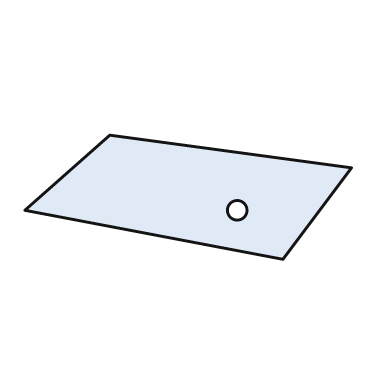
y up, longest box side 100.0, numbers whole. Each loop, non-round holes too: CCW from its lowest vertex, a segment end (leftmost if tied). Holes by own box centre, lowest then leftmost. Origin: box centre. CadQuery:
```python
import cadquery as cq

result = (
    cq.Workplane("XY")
    .moveTo(29.0, -19.0)
    .lineTo(50.0, 9.0)
    .lineTo(-24.0, 19.0)
    .lineTo(-50.0, -4.0)
    .close()
    .moveTo(15.0, -4.0)
    .circle(3.0)
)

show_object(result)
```